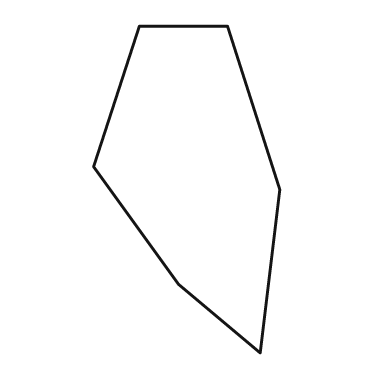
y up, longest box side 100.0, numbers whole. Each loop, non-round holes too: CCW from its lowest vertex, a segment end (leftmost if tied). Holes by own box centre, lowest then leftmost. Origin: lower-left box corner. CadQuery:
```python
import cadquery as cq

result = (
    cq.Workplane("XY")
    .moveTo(51.0, 0.0)
    .lineTo(57.0, 50.0)
    .lineTo(41.0, 100.0)
    .lineTo(14.0, 100.0)
    .lineTo(0.0, 57.0)
    .lineTo(26.0, 21.0)
    .close()
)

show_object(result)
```